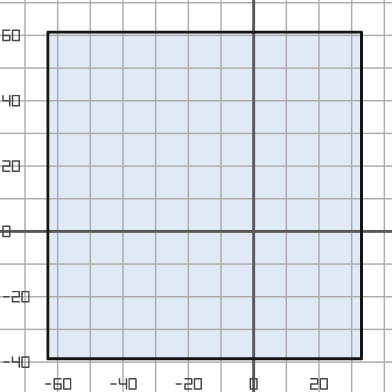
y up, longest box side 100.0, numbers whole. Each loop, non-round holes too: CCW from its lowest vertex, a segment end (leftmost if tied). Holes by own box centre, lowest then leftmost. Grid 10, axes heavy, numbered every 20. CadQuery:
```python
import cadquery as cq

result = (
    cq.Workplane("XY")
    .moveTo(-63.0, -39.0)
    .lineTo(33.0, -39.0)
    .lineTo(33.0, 61.0)
    .lineTo(-63.0, 61.0)
    .close()
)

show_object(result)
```